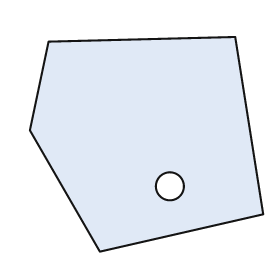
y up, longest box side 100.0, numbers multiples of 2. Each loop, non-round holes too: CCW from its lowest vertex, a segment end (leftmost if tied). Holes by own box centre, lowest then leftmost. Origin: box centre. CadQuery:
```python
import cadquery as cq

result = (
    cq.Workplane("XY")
    .moveTo(-20.0, -46.0)
    .lineTo(50.0, -30.0)
    .lineTo(38.0, 46.0)
    .lineTo(-42.0, 44.0)
    .lineTo(-50.0, 6.0)
    .close()
    .moveTo(10.0, -18.0)
    .circle(6.0)
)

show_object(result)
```